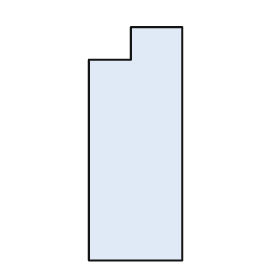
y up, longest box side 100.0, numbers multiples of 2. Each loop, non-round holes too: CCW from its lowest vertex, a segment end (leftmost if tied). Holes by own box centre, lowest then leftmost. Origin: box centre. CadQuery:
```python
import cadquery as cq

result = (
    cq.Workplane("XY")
    .moveTo(-20.0, -50.0)
    .lineTo(20.0, -50.0)
    .lineTo(20.0, 50.0)
    .lineTo(-2.0, 50.0)
    .lineTo(-2.0, 36.0)
    .lineTo(-20.0, 36.0)
    .close()
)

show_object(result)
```